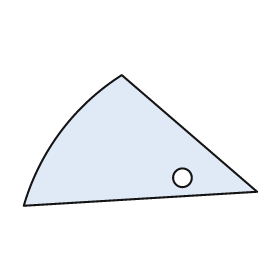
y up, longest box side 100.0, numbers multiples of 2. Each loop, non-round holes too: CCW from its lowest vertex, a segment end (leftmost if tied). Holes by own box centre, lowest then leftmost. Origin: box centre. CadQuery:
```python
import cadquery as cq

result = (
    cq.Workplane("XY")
    .moveTo(-50.0, -28.0)
    .lineTo(50.0, -22.0)
    .lineTo(-8.0, 28.0)
    .threePointArc((-34.0, 4.0), (-50.0, -28.0))
    .close()
    .moveTo(18.0, -16.0)
    .circle(4.0)
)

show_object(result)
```